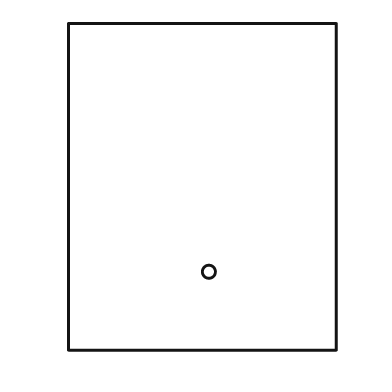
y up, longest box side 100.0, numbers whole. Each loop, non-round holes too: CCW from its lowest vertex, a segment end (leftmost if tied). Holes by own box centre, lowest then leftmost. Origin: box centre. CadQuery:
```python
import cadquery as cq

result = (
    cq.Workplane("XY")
    .moveTo(-41.0, -50.0)
    .lineTo(41.0, -50.0)
    .lineTo(41.0, 50.0)
    .lineTo(-41.0, 50.0)
    .close()
    .moveTo(2.0, -26.0)
    .circle(2.0)
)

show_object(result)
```